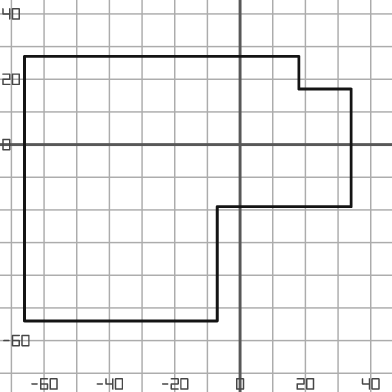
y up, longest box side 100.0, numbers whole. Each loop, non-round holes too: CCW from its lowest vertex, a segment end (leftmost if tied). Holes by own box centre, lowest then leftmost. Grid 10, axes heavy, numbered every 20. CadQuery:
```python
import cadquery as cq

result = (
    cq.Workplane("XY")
    .moveTo(-66.0, -54.0)
    .lineTo(-7.0, -54.0)
    .lineTo(-7.0, -19.0)
    .lineTo(34.0, -19.0)
    .lineTo(34.0, 17.0)
    .lineTo(18.0, 17.0)
    .lineTo(18.0, 27.0)
    .lineTo(-66.0, 27.0)
    .close()
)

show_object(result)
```